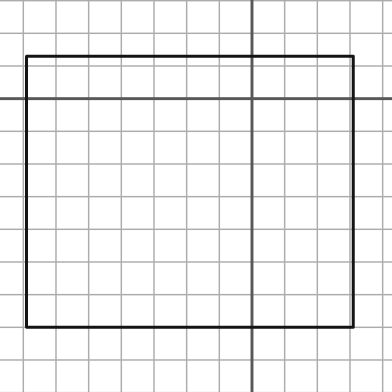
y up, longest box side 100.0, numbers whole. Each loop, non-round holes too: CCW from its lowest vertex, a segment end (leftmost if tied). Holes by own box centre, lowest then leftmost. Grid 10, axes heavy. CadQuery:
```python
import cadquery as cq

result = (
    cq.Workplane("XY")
    .moveTo(-69.0, -70.0)
    .lineTo(31.0, -70.0)
    .lineTo(31.0, 13.0)
    .lineTo(-69.0, 13.0)
    .close()
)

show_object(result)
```